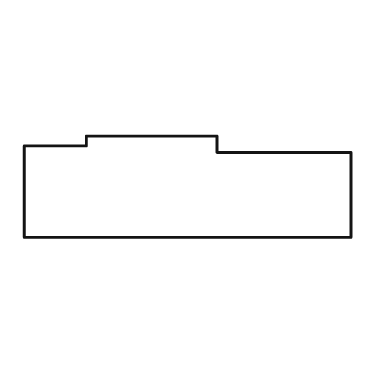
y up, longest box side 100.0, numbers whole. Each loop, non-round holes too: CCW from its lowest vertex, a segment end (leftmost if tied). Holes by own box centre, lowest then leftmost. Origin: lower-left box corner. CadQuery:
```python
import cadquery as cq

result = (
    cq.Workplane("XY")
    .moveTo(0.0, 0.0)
    .lineTo(100.0, 0.0)
    .lineTo(100.0, 26.0)
    .lineTo(59.0, 26.0)
    .lineTo(59.0, 31.0)
    .lineTo(19.0, 31.0)
    .lineTo(19.0, 28.0)
    .lineTo(0.0, 28.0)
    .close()
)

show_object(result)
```